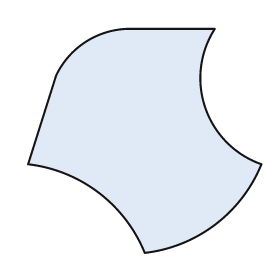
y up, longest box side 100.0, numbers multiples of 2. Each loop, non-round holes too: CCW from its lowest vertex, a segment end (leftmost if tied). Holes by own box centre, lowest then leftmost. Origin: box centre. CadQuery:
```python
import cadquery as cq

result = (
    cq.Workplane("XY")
    .moveTo(0.0, -48.0)
    .threePointArc((30.0, -36.0), (50.0, -10.0))
    .threePointArc((26.0, 14.0), (30.0, 48.0))
    .lineTo(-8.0, 48.0)
    .threePointArc((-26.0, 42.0), (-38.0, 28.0))
    .lineTo(-50.0, -10.0)
    .threePointArc((-20.0, -22.0), (0.0, -48.0))
    .close()
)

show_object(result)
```